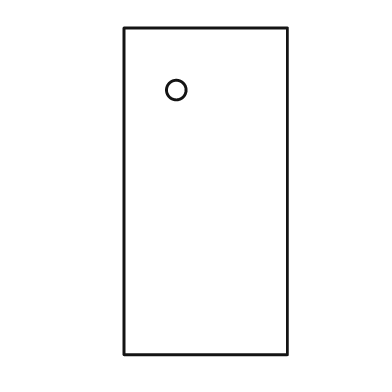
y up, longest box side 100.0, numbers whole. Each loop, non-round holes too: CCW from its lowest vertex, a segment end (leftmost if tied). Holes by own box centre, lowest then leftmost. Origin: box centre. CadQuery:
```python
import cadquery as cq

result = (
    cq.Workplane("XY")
    .moveTo(-25.0, -50.0)
    .lineTo(25.0, -50.0)
    .lineTo(25.0, 50.0)
    .lineTo(-25.0, 50.0)
    .close()
    .moveTo(-9.0, 31.0)
    .circle(3.0)
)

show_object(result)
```